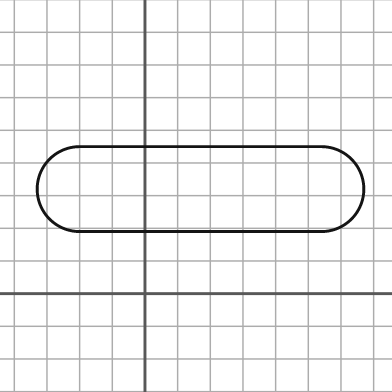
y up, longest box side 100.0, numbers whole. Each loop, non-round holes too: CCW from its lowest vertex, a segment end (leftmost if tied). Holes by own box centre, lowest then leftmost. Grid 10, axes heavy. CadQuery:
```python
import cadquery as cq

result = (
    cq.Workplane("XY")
    .moveTo(-20.0, 19.0)
    .lineTo(54.0, 19.0)
    .threePointArc((67.0, 32.0), (54.0, 45.0))
    .lineTo(-20.0, 45.0)
    .threePointArc((-33.0, 32.0), (-20.0, 19.0))
    .close()
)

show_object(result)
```